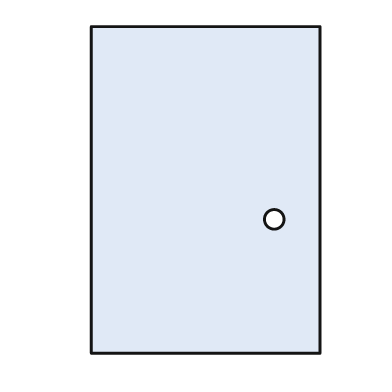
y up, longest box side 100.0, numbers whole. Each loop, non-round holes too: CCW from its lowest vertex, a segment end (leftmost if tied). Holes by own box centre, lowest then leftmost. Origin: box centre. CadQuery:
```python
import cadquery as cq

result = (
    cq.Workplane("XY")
    .moveTo(-35.0, -50.0)
    .lineTo(35.0, -50.0)
    .lineTo(35.0, 50.0)
    .lineTo(-35.0, 50.0)
    .close()
    .moveTo(21.0, -9.0)
    .circle(3.0)
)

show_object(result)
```